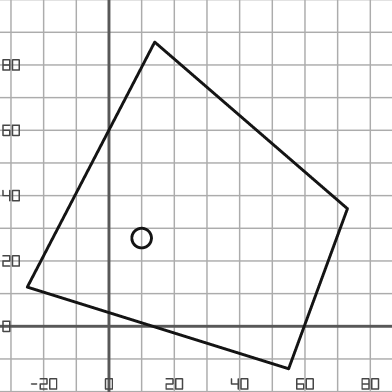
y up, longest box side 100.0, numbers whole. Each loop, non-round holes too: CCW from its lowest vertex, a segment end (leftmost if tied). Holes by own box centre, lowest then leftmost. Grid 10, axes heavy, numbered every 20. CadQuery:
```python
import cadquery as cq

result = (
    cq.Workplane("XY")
    .moveTo(55.0, -13.0)
    .lineTo(73.0, 36.0)
    .lineTo(14.0, 87.0)
    .lineTo(-25.0, 12.0)
    .close()
    .moveTo(10.0, 27.0)
    .circle(3.0)
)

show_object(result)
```